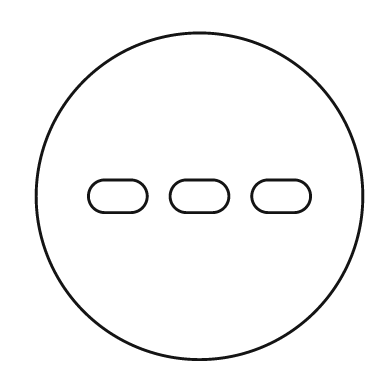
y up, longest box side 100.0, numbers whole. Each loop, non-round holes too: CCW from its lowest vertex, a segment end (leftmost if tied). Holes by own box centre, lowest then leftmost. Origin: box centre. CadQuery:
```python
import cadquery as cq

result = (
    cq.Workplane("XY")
    .moveTo(0.0, 0.0)
    .circle(50.0)
    .moveTo(-29.0, -5.0)
    .lineTo(-21.0, -5.0)
    .threePointArc((-16.0, 0.0), (-21.0, 5.0))
    .lineTo(-29.0, 5.0)
    .threePointArc((-34.0, 0.0), (-29.0, -5.0))
    .close()
    .moveTo(-4.0, -5.0)
    .lineTo(4.0, -5.0)
    .threePointArc((9.0, 0.0), (4.0, 5.0))
    .lineTo(-4.0, 5.0)
    .threePointArc((-9.0, 0.0), (-4.0, -5.0))
    .close()
    .moveTo(21.0, -5.0)
    .lineTo(29.0, -5.0)
    .threePointArc((34.0, 0.0), (29.0, 5.0))
    .lineTo(21.0, 5.0)
    .threePointArc((16.0, 0.0), (21.0, -5.0))
    .close()
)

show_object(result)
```